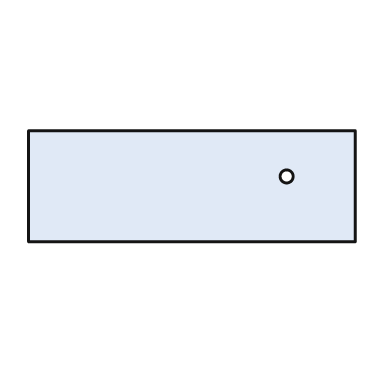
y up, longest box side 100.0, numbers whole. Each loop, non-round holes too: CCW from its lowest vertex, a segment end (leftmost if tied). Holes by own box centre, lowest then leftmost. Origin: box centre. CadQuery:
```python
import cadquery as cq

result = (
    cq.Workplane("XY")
    .moveTo(-50.0, -17.0)
    .lineTo(50.0, -17.0)
    .lineTo(50.0, 17.0)
    .lineTo(-50.0, 17.0)
    .close()
    .moveTo(29.0, 3.0)
    .circle(2.0)
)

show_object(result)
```